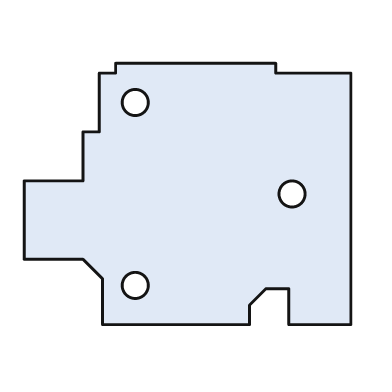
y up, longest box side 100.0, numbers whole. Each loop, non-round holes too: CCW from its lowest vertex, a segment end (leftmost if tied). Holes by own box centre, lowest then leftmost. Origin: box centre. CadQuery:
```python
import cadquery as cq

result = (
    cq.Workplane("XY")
    .moveTo(-26.0, -40.0)
    .lineTo(19.0, -40.0)
    .lineTo(19.0, -34.0)
    .lineTo(24.0, -29.0)
    .lineTo(31.0, -29.0)
    .lineTo(31.0, -40.0)
    .lineTo(50.0, -40.0)
    .lineTo(50.0, 37.0)
    .lineTo(27.0, 37.0)
    .lineTo(27.0, 40.0)
    .lineTo(-22.0, 40.0)
    .lineTo(-22.0, 37.0)
    .lineTo(-27.0, 37.0)
    .lineTo(-27.0, 19.0)
    .lineTo(-32.0, 19.0)
    .lineTo(-32.0, 4.0)
    .lineTo(-50.0, 4.0)
    .lineTo(-50.0, -20.0)
    .lineTo(-32.0, -20.0)
    .lineTo(-26.0, -26.0)
    .close()
    .moveTo(-16.0, -28.0)
    .circle(4.0)
    .moveTo(32.0, 0.0)
    .circle(4.0)
    .moveTo(-16.0, 28.0)
    .circle(4.0)
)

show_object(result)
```